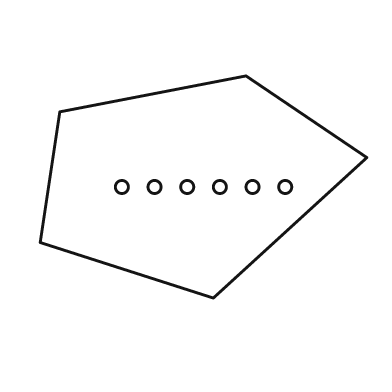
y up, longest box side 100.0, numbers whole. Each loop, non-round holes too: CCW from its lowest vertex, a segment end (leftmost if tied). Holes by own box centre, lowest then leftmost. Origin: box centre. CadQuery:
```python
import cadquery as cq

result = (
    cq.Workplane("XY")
    .moveTo(3.0, -34.0)
    .lineTo(50.0, 9.0)
    .lineTo(13.0, 34.0)
    .lineTo(-44.0, 23.0)
    .lineTo(-50.0, -17.0)
    .close()
    .moveTo(-25.0, 0.0)
    .circle(2.0)
    .moveTo(-15.0, 0.0)
    .circle(2.0)
    .moveTo(-5.0, 0.0)
    .circle(2.0)
    .moveTo(5.0, 0.0)
    .circle(2.0)
    .moveTo(15.0, 0.0)
    .circle(2.0)
    .moveTo(25.0, 0.0)
    .circle(2.0)
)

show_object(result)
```